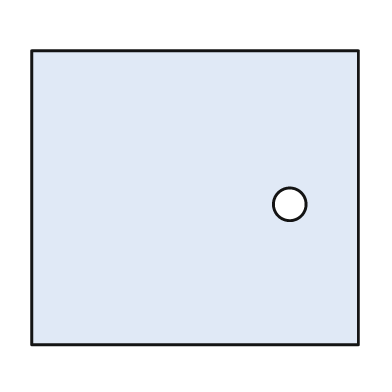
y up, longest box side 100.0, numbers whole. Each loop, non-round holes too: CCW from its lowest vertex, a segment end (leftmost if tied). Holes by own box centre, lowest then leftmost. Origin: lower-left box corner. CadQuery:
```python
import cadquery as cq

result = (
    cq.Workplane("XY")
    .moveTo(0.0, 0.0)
    .lineTo(100.0, 0.0)
    .lineTo(100.0, 90.0)
    .lineTo(0.0, 90.0)
    .close()
    .moveTo(79.0, 43.0)
    .circle(5.0)
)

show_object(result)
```